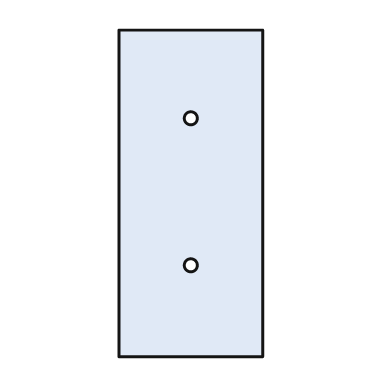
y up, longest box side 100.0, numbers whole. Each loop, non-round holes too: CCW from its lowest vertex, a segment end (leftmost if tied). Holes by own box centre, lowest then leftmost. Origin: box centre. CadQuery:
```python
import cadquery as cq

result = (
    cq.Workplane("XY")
    .moveTo(-22.0, -50.0)
    .lineTo(22.0, -50.0)
    .lineTo(22.0, 50.0)
    .lineTo(-22.0, 50.0)
    .close()
    .moveTo(0.0, -22.0)
    .circle(2.0)
    .moveTo(0.0, 23.0)
    .circle(2.0)
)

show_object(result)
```